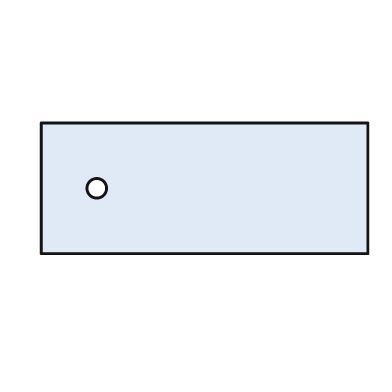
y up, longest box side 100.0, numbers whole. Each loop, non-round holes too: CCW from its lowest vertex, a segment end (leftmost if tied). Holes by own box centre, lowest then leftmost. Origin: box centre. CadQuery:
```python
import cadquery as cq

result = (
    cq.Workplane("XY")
    .moveTo(-50.0, -20.0)
    .lineTo(50.0, -20.0)
    .lineTo(50.0, 20.0)
    .lineTo(-50.0, 20.0)
    .close()
    .moveTo(-33.0, 0.0)
    .circle(3.0)
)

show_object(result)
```